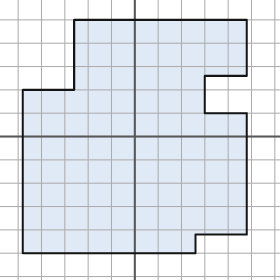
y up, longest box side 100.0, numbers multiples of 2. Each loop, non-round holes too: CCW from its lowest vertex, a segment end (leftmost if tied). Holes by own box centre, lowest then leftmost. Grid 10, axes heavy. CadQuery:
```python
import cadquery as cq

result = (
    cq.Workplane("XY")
    .moveTo(-48.0, -50.0)
    .lineTo(26.0, -50.0)
    .lineTo(26.0, -42.0)
    .lineTo(48.0, -42.0)
    .lineTo(48.0, 10.0)
    .lineTo(30.0, 10.0)
    .lineTo(30.0, 26.0)
    .lineTo(48.0, 26.0)
    .lineTo(48.0, 50.0)
    .lineTo(-26.0, 50.0)
    .lineTo(-26.0, 20.0)
    .lineTo(-48.0, 20.0)
    .close()
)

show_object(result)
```